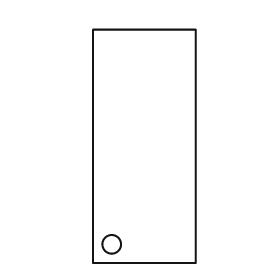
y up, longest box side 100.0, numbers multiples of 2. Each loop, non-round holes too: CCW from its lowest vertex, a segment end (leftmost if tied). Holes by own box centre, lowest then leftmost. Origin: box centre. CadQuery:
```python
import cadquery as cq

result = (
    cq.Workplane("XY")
    .moveTo(-22.0, -50.0)
    .lineTo(22.0, -50.0)
    .lineTo(22.0, 50.0)
    .lineTo(-22.0, 50.0)
    .close()
    .moveTo(-14.0, -42.0)
    .circle(4.0)
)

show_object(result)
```